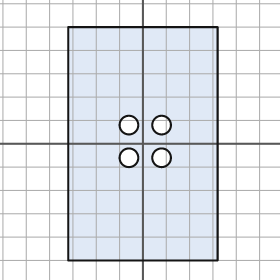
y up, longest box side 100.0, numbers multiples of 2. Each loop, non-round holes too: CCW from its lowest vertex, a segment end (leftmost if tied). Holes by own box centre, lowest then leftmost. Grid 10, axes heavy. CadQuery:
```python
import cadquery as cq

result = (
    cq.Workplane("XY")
    .moveTo(-32.0, -50.0)
    .lineTo(32.0, -50.0)
    .lineTo(32.0, 50.0)
    .lineTo(-32.0, 50.0)
    .close()
    .moveTo(-6.0, -6.0)
    .circle(4.0)
    .moveTo(8.0, -6.0)
    .circle(4.0)
    .moveTo(-6.0, 8.0)
    .circle(4.0)
    .moveTo(8.0, 8.0)
    .circle(4.0)
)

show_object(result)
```